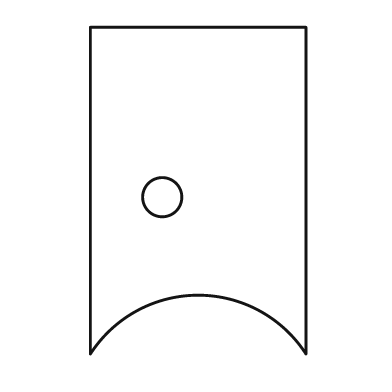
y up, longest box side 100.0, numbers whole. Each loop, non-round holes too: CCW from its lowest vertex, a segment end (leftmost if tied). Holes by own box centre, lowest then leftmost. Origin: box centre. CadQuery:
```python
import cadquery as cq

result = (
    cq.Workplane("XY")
    .moveTo(-33.0, -50.0)
    .threePointArc((0.0, -32.0), (33.0, -50.0))
    .lineTo(33.0, 50.0)
    .lineTo(-33.0, 50.0)
    .close()
    .moveTo(-11.0, -2.0)
    .circle(6.0)
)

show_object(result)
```